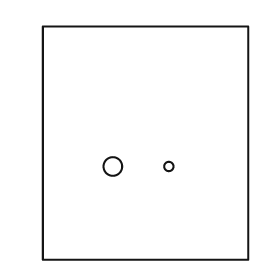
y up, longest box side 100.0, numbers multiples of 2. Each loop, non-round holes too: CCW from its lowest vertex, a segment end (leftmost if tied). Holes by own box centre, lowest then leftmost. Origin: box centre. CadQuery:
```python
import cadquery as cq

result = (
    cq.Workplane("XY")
    .moveTo(-44.0, -50.0)
    .lineTo(44.0, -50.0)
    .lineTo(44.0, 50.0)
    .lineTo(-44.0, 50.0)
    .close()
    .moveTo(-14.0, -10.0)
    .circle(4.0)
    .moveTo(10.0, -10.0)
    .circle(2.0)
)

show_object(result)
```